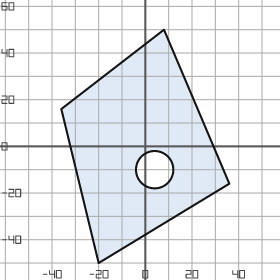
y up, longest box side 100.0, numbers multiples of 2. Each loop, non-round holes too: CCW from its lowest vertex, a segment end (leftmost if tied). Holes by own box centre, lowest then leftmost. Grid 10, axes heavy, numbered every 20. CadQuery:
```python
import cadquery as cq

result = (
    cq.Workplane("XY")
    .moveTo(-20.0, -50.0)
    .lineTo(36.0, -16.0)
    .lineTo(8.0, 50.0)
    .lineTo(-36.0, 16.0)
    .close()
    .moveTo(4.0, -10.0)
    .circle(8.0)
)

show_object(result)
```